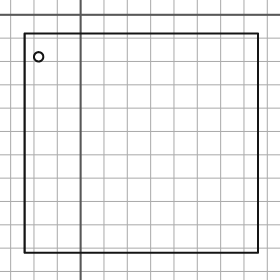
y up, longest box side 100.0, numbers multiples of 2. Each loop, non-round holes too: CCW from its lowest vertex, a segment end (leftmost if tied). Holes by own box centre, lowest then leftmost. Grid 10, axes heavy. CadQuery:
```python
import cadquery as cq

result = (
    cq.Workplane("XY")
    .moveTo(-24.0, -102.0)
    .lineTo(76.0, -102.0)
    .lineTo(76.0, -8.0)
    .lineTo(-24.0, -8.0)
    .close()
    .moveTo(-18.0, -18.0)
    .circle(2.0)
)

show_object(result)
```